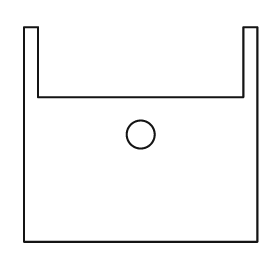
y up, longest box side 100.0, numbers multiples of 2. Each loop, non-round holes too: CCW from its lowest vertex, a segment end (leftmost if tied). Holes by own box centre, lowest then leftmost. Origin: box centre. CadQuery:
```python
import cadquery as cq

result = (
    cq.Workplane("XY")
    .moveTo(-50.0, -46.0)
    .lineTo(50.0, -46.0)
    .lineTo(50.0, 46.0)
    .lineTo(44.0, 46.0)
    .lineTo(44.0, 16.0)
    .lineTo(-44.0, 16.0)
    .lineTo(-44.0, 46.0)
    .lineTo(-50.0, 46.0)
    .close()
    .moveTo(0.0, 0.0)
    .circle(6.0)
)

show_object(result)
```